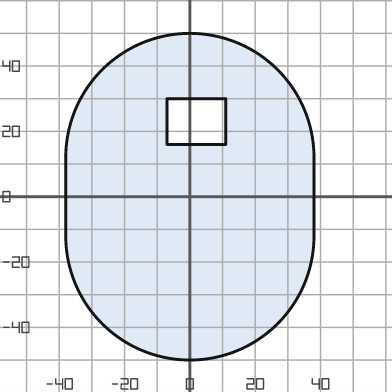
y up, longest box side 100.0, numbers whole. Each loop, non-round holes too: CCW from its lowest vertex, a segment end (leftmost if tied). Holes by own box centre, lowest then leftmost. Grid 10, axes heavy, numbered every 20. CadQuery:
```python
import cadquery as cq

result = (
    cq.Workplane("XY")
    .moveTo(-38.0, -12.0)
    .threePointArc((0.0, -50.0), (38.0, -12.0))
    .lineTo(38.0, 12.0)
    .threePointArc((0.0, 50.0), (-38.0, 12.0))
    .close()
    .moveTo(-7.0, 16.0)
    .lineTo(11.0, 16.0)
    .lineTo(11.0, 30.0)
    .lineTo(-7.0, 30.0)
    .close()
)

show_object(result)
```